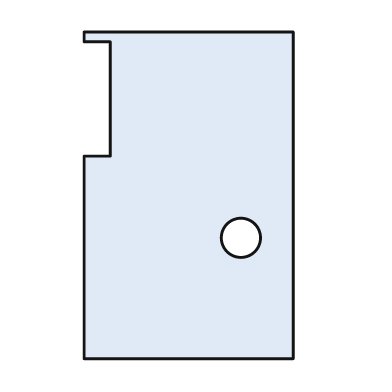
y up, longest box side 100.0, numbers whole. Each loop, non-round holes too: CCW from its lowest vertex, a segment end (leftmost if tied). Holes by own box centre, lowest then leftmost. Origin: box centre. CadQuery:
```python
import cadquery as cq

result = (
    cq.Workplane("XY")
    .moveTo(-32.0, -50.0)
    .lineTo(32.0, -50.0)
    .lineTo(32.0, 50.0)
    .lineTo(-32.0, 50.0)
    .lineTo(-32.0, 47.0)
    .lineTo(-24.0, 47.0)
    .lineTo(-24.0, 12.0)
    .lineTo(-32.0, 12.0)
    .close()
    .moveTo(16.0, -13.0)
    .circle(6.0)
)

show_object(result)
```